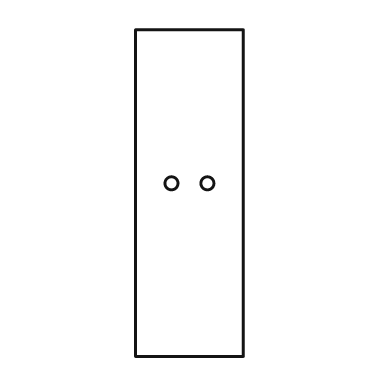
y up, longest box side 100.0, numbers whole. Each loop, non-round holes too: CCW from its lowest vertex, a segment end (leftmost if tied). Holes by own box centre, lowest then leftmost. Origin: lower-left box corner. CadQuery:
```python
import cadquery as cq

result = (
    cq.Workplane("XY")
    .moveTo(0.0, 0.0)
    .lineTo(33.0, 0.0)
    .lineTo(33.0, 100.0)
    .lineTo(0.0, 100.0)
    .close()
    .moveTo(11.0, 53.0)
    .circle(2.0)
    .moveTo(22.0, 53.0)
    .circle(2.0)
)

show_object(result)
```